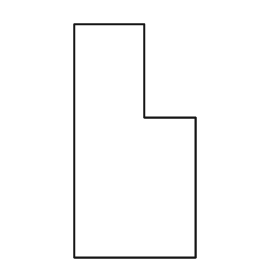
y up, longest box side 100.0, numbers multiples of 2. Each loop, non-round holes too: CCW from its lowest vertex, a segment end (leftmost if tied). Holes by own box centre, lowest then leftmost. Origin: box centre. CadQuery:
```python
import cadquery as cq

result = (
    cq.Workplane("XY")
    .moveTo(-26.0, -50.0)
    .lineTo(26.0, -50.0)
    .lineTo(26.0, 10.0)
    .lineTo(4.0, 10.0)
    .lineTo(4.0, 50.0)
    .lineTo(-26.0, 50.0)
    .close()
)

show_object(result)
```